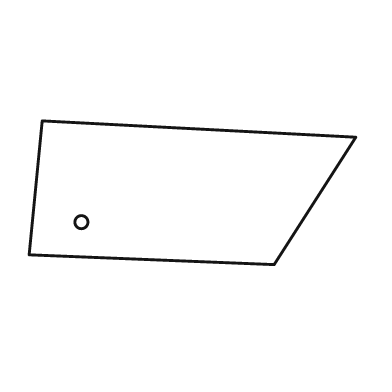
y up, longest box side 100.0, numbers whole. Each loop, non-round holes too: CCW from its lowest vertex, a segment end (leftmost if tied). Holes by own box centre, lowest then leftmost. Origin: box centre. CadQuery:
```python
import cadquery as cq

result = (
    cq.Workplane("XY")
    .moveTo(25.0, -22.0)
    .lineTo(50.0, 17.0)
    .lineTo(-46.0, 22.0)
    .lineTo(-50.0, -19.0)
    .close()
    .moveTo(-34.0, -9.0)
    .circle(2.0)
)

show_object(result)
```